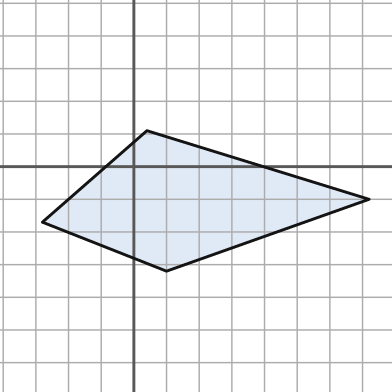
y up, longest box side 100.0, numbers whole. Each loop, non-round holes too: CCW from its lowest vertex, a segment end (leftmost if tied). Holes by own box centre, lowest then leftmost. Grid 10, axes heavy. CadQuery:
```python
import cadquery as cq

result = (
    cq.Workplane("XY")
    .moveTo(10.0, -32.0)
    .lineTo(72.0, -10.0)
    .lineTo(4.0, 11.0)
    .lineTo(-28.0, -17.0)
    .close()
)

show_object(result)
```